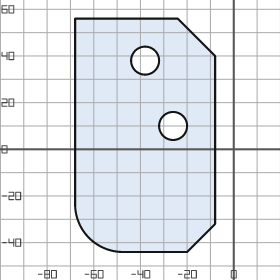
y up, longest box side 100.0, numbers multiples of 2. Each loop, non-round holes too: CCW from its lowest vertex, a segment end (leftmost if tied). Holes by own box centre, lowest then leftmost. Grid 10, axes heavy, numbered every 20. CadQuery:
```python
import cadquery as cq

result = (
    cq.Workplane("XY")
    .moveTo(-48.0, -44.0)
    .lineTo(-20.0, -44.0)
    .lineTo(-8.0, -32.0)
    .lineTo(-8.0, 40.0)
    .lineTo(-24.0, 56.0)
    .lineTo(-68.0, 56.0)
    .lineTo(-68.0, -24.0)
    .threePointArc((-62.0, -38.0), (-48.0, -44.0))
    .close()
    .moveTo(-26.0, 10.0)
    .circle(6.0)
    .moveTo(-38.0, 38.0)
    .circle(6.0)
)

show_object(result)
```